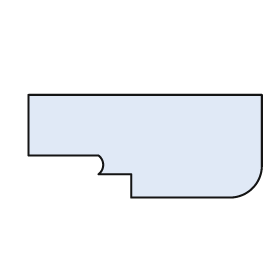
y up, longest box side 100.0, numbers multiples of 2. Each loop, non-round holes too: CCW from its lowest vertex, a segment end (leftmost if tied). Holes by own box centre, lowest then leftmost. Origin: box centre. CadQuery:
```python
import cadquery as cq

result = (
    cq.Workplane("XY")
    .moveTo(-6.0, -22.0)
    .lineTo(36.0, -22.0)
    .threePointArc((46.0, -18.0), (50.0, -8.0))
    .lineTo(50.0, 22.0)
    .lineTo(-50.0, 22.0)
    .lineTo(-50.0, -4.0)
    .lineTo(-20.0, -4.0)
    .threePointArc((-18.0, -8.0), (-20.0, -12.0))
    .lineTo(-6.0, -12.0)
    .close()
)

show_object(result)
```